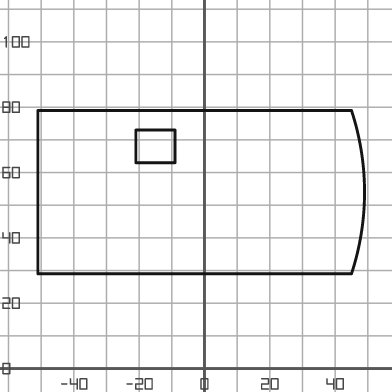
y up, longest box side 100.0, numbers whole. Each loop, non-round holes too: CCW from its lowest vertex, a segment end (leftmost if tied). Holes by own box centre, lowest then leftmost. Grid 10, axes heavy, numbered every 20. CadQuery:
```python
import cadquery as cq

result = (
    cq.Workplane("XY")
    .moveTo(-51.0, 29.0)
    .lineTo(45.0, 29.0)
    .threePointArc((49.0, 54.0), (45.0, 79.0))
    .lineTo(-51.0, 79.0)
    .close()
    .moveTo(-21.0, 63.0)
    .lineTo(-9.0, 63.0)
    .lineTo(-9.0, 73.0)
    .lineTo(-21.0, 73.0)
    .close()
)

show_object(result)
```